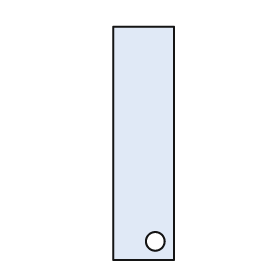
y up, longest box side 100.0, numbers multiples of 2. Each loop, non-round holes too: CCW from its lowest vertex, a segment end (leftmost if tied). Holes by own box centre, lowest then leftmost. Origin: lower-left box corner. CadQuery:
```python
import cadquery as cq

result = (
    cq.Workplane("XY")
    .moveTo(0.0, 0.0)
    .lineTo(26.0, 0.0)
    .lineTo(26.0, 100.0)
    .lineTo(0.0, 100.0)
    .close()
    .moveTo(18.0, 8.0)
    .circle(4.0)
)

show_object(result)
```